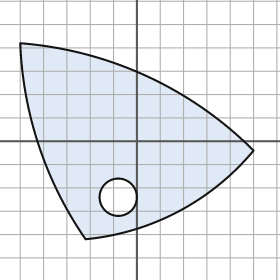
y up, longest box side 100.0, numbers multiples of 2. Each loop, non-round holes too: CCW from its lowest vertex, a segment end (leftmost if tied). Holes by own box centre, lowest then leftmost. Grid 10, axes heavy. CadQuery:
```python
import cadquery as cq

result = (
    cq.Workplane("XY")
    .moveTo(-22.0, -42.0)
    .threePointArc((18.0, -30.0), (50.0, -4.0))
    .threePointArc((4.0, 28.0), (-50.0, 42.0))
    .threePointArc((-42.0, -2.0), (-22.0, -42.0))
    .close()
    .moveTo(-8.0, -24.0)
    .circle(8.0)
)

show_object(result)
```